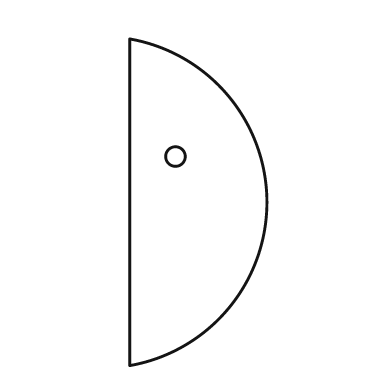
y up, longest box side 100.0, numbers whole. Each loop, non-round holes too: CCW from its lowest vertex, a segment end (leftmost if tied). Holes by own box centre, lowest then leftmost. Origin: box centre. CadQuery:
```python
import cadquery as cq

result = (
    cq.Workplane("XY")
    .moveTo(-21.0, -50.0)
    .threePointArc((21.0, 0.0), (-21.0, 50.0))
    .close()
    .moveTo(-7.0, 14.0)
    .circle(3.0)
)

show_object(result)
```